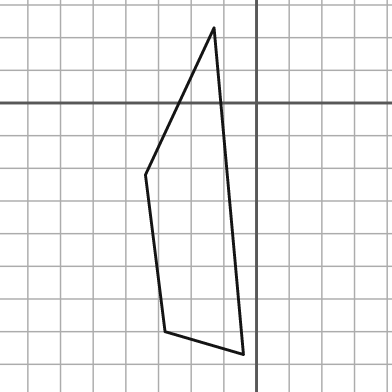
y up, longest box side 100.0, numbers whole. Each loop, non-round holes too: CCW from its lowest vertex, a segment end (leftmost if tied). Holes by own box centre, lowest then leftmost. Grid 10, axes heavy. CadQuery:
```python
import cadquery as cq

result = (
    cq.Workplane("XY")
    .moveTo(-4.0, -77.0)
    .lineTo(-13.0, 23.0)
    .lineTo(-34.0, -22.0)
    .lineTo(-28.0, -70.0)
    .close()
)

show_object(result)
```